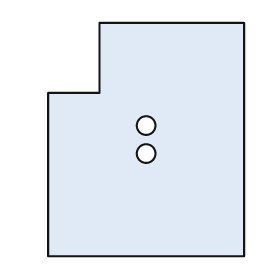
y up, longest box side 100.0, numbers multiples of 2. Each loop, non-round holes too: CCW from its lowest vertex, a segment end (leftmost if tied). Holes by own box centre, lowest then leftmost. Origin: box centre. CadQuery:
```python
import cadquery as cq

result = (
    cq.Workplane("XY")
    .moveTo(-42.0, -50.0)
    .lineTo(42.0, -50.0)
    .lineTo(42.0, 50.0)
    .lineTo(-20.0, 50.0)
    .lineTo(-20.0, 20.0)
    .lineTo(-42.0, 20.0)
    .close()
    .moveTo(0.0, -6.0)
    .circle(4.0)
    .moveTo(0.0, 6.0)
    .circle(4.0)
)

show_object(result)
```